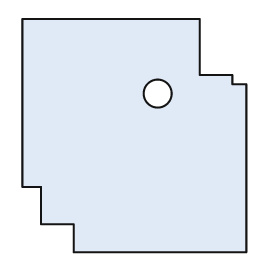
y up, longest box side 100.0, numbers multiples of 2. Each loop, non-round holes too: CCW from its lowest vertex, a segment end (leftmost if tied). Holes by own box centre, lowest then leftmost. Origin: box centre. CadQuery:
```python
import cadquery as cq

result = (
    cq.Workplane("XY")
    .moveTo(-26.0, -50.0)
    .lineTo(48.0, -50.0)
    .lineTo(48.0, 22.0)
    .lineTo(42.0, 22.0)
    .lineTo(42.0, 26.0)
    .lineTo(28.0, 26.0)
    .lineTo(28.0, 50.0)
    .lineTo(-48.0, 50.0)
    .lineTo(-48.0, -22.0)
    .lineTo(-40.0, -22.0)
    .lineTo(-40.0, -38.0)
    .lineTo(-26.0, -38.0)
    .close()
    .moveTo(10.0, 18.0)
    .circle(6.0)
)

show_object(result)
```